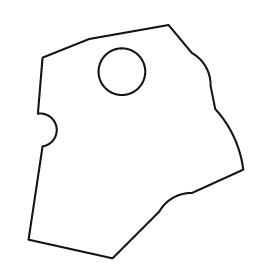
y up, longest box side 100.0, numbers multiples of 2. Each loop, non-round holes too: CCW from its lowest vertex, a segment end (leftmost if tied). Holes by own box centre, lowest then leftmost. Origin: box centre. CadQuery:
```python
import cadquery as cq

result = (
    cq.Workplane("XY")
    .moveTo(-10.0, -50.0)
    .lineTo(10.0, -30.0)
    .threePointArc((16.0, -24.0), (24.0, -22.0))
    .lineTo(46.0, -12.0)
    .threePointArc((42.0, 2.0), (34.0, 14.0))
    .lineTo(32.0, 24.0)
    .threePointArc((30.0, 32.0), (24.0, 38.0))
    .lineTo(14.0, 50.0)
    .lineTo(-20.0, 44.0)
    .lineTo(-40.0, 36.0)
    .lineTo(-42.0, 12.0)
    .threePointArc((-34.0, 6.0), (-40.0, -2.0))
    .lineTo(-46.0, -42.0)
    .close()
    .moveTo(-6.0, 30.0)
    .circle(10.0)
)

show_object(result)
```